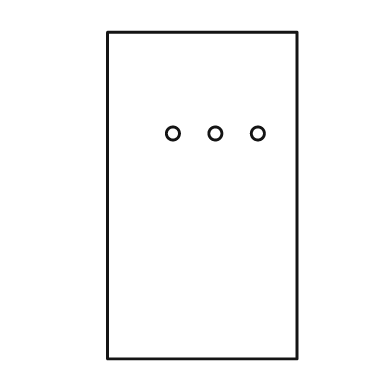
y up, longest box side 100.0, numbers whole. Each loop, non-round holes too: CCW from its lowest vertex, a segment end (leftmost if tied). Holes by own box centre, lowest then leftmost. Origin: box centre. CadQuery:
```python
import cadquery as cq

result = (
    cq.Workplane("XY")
    .moveTo(-29.0, -50.0)
    .lineTo(29.0, -50.0)
    .lineTo(29.0, 50.0)
    .lineTo(-29.0, 50.0)
    .close()
    .moveTo(-9.0, 19.0)
    .circle(2.0)
    .moveTo(4.0, 19.0)
    .circle(2.0)
    .moveTo(17.0, 19.0)
    .circle(2.0)
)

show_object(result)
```